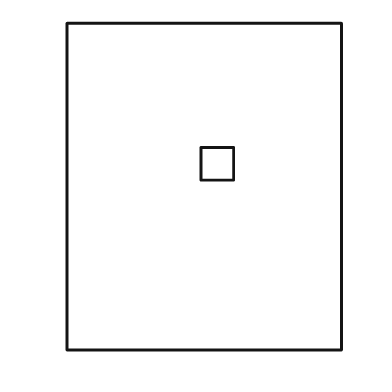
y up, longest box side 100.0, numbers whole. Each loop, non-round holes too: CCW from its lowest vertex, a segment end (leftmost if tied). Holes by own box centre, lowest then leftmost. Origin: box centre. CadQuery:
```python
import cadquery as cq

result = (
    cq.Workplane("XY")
    .moveTo(-42.0, -50.0)
    .lineTo(42.0, -50.0)
    .lineTo(42.0, 50.0)
    .lineTo(-42.0, 50.0)
    .close()
    .moveTo(-1.0, 2.0)
    .lineTo(9.0, 2.0)
    .lineTo(9.0, 12.0)
    .lineTo(-1.0, 12.0)
    .close()
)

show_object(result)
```